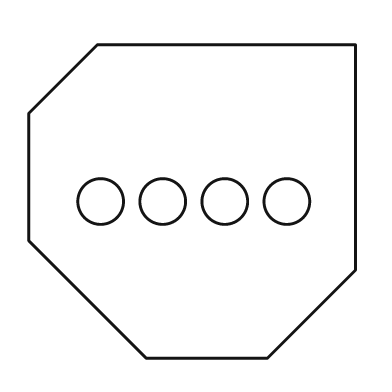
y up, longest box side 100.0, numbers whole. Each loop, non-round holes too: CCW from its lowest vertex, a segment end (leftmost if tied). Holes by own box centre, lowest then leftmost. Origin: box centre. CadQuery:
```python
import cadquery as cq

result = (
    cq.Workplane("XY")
    .moveTo(-14.0, -48.0)
    .lineTo(23.0, -48.0)
    .lineTo(50.0, -21.0)
    .lineTo(50.0, 48.0)
    .lineTo(-29.0, 48.0)
    .lineTo(-50.0, 27.0)
    .lineTo(-50.0, -12.0)
    .close()
    .moveTo(-28.0, 0.0)
    .circle(7.0)
    .moveTo(-9.0, 0.0)
    .circle(7.0)
    .moveTo(10.0, 0.0)
    .circle(7.0)
    .moveTo(29.0, 0.0)
    .circle(7.0)
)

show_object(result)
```